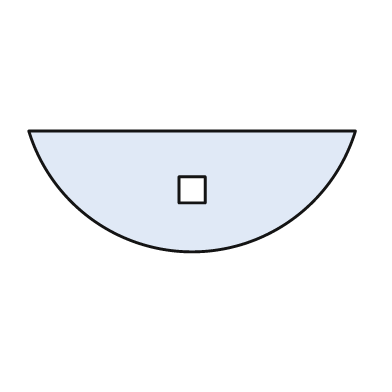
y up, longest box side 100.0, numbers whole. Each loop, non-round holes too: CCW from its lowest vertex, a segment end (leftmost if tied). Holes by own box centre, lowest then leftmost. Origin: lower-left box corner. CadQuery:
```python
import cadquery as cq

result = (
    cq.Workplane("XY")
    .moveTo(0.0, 37.0)
    .threePointArc((50.0, 0.0), (100.0, 37.0))
    .close()
    .moveTo(46.0, 15.0)
    .lineTo(54.0, 15.0)
    .lineTo(54.0, 23.0)
    .lineTo(46.0, 23.0)
    .close()
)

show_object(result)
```